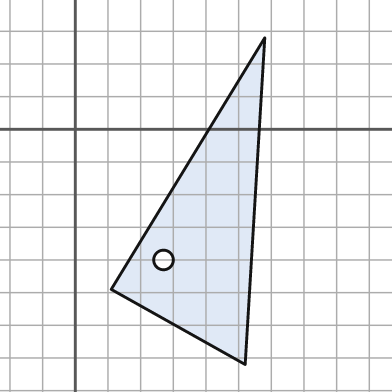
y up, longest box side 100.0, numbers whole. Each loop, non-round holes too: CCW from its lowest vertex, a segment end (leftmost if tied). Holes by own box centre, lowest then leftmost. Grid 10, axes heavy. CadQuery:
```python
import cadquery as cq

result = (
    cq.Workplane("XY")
    .moveTo(52.0, -72.0)
    .lineTo(58.0, 28.0)
    .lineTo(11.0, -49.0)
    .close()
    .moveTo(27.0, -40.0)
    .circle(3.0)
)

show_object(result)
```